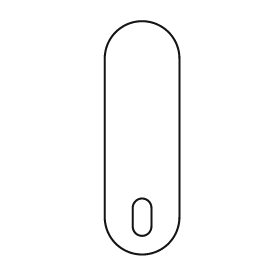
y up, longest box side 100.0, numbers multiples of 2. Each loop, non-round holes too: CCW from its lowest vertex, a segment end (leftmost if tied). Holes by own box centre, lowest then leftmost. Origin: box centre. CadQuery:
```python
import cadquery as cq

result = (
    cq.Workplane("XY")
    .moveTo(-16.0, -34.0)
    .threePointArc((0.0, -50.0), (16.0, -34.0))
    .lineTo(16.0, 34.0)
    .threePointArc((0.0, 50.0), (-16.0, 34.0))
    .close()
    .moveTo(-4.0, -38.0)
    .threePointArc((0.0, -42.0), (4.0, -38.0))
    .lineTo(4.0, -30.0)
    .threePointArc((0.0, -26.0), (-4.0, -30.0))
    .close()
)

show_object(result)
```